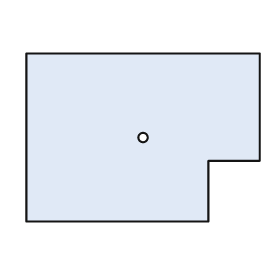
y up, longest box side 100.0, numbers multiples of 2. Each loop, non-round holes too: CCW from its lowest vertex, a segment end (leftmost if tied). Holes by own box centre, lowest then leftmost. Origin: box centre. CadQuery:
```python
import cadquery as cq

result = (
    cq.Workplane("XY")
    .moveTo(-50.0, -36.0)
    .lineTo(28.0, -36.0)
    .lineTo(28.0, -10.0)
    .lineTo(50.0, -10.0)
    .lineTo(50.0, 36.0)
    .lineTo(-50.0, 36.0)
    .close()
    .moveTo(0.0, 0.0)
    .circle(2.0)
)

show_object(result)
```